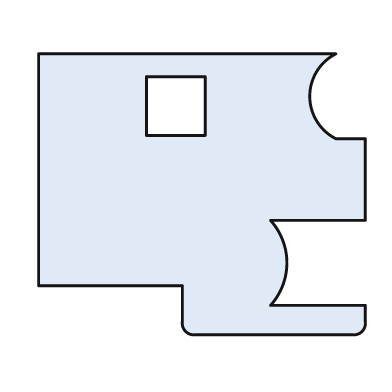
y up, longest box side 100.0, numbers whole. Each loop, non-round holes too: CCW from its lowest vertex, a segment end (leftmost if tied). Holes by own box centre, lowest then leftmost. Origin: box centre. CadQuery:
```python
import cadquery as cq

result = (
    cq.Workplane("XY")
    .moveTo(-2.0, -43.0)
    .lineTo(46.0, -43.0)
    .threePointArc((49.0, -42.0), (50.0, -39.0))
    .lineTo(50.0, -34.0)
    .lineTo(21.0, -34.0)
    .threePointArc((26.0, -21.0), (21.0, -8.0))
    .lineTo(50.0, -8.0)
    .lineTo(50.0, 17.0)
    .lineTo(41.0, 17.0)
    .threePointArc((33.0, 30.0), (41.0, 43.0))
    .lineTo(-50.0, 43.0)
    .lineTo(-50.0, -28.0)
    .lineTo(-6.0, -28.0)
    .lineTo(-6.0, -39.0)
    .threePointArc((-5.0, -42.0), (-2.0, -43.0))
    .close()
    .moveTo(-17.0, 18.0)
    .lineTo(1.0, 18.0)
    .lineTo(1.0, 36.0)
    .lineTo(-17.0, 36.0)
    .close()
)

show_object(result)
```